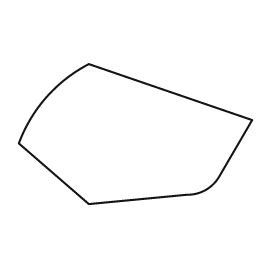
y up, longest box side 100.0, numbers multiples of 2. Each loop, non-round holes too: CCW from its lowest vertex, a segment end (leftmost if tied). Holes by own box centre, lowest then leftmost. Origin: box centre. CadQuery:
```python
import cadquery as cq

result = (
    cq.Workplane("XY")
    .moveTo(-20.0, -30.0)
    .lineTo(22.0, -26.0)
    .threePointArc((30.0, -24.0), (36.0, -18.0))
    .lineTo(50.0, 6.0)
    .lineTo(-20.0, 30.0)
    .threePointArc((-38.0, 16.0), (-50.0, -4.0))
    .close()
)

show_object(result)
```